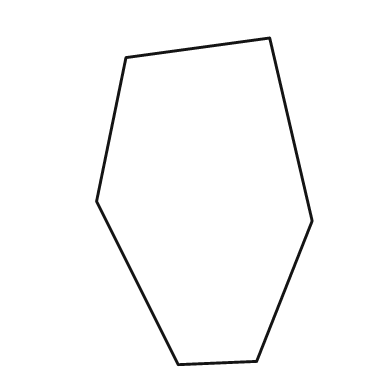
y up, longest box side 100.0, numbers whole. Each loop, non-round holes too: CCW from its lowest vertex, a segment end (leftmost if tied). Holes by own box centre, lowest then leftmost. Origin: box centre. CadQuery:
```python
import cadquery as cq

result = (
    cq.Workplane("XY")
    .moveTo(-8.0, -50.0)
    .lineTo(16.0, -49.0)
    .lineTo(33.0, -6.0)
    .lineTo(20.0, 50.0)
    .lineTo(-24.0, 44.0)
    .lineTo(-33.0, 0.0)
    .close()
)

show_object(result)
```